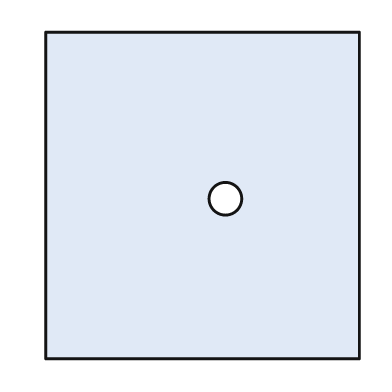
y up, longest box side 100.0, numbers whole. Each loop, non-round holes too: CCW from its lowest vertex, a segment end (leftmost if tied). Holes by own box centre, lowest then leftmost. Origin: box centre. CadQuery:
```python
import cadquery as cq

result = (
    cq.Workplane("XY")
    .moveTo(-48.0, -50.0)
    .lineTo(48.0, -50.0)
    .lineTo(48.0, 50.0)
    .lineTo(-48.0, 50.0)
    .close()
    .moveTo(7.0, -1.0)
    .circle(5.0)
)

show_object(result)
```